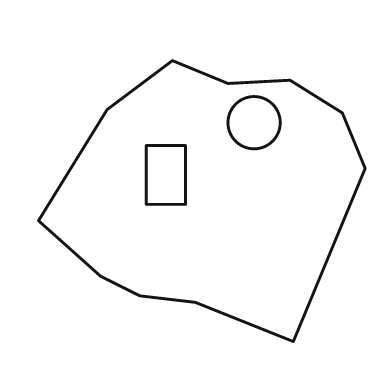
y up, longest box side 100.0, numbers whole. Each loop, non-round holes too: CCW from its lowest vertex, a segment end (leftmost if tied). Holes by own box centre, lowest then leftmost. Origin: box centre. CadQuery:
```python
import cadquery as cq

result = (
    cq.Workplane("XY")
    .moveTo(28.0, -43.0)
    .lineTo(50.0, 10.0)
    .lineTo(43.0, 27.0)
    .lineTo(27.0, 37.0)
    .lineTo(8.0, 36.0)
    .lineTo(-9.0, 43.0)
    .lineTo(-29.0, 28.0)
    .lineTo(-50.0, -6.0)
    .lineTo(-31.0, -23.0)
    .lineTo(-19.0, -29.0)
    .lineTo(-2.0, -31.0)
    .close()
    .moveTo(-17.0, -1.0)
    .lineTo(-5.0, -1.0)
    .lineTo(-5.0, 17.0)
    .lineTo(-17.0, 17.0)
    .close()
    .moveTo(16.0, 24.0)
    .circle(8.0)
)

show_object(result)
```